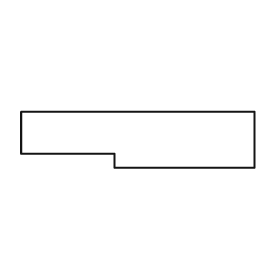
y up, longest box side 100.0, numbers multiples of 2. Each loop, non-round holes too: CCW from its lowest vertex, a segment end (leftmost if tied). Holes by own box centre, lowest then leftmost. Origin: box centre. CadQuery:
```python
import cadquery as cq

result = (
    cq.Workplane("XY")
    .moveTo(-10.0, -12.0)
    .lineTo(50.0, -12.0)
    .lineTo(50.0, 12.0)
    .lineTo(-50.0, 12.0)
    .lineTo(-50.0, -6.0)
    .lineTo(-10.0, -6.0)
    .close()
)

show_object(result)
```